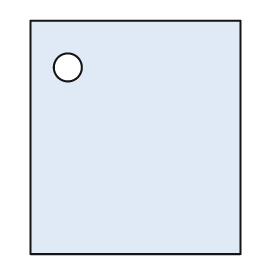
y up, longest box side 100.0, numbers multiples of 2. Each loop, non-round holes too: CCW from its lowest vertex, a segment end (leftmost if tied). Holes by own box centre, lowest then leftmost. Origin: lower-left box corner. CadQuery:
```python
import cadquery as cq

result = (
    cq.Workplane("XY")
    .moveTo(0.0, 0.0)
    .lineTo(90.0, 0.0)
    .lineTo(90.0, 100.0)
    .lineTo(0.0, 100.0)
    .close()
    .moveTo(16.0, 80.0)
    .circle(6.0)
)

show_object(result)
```